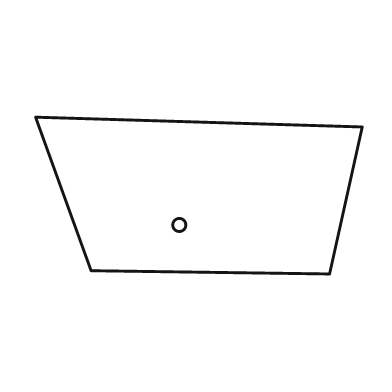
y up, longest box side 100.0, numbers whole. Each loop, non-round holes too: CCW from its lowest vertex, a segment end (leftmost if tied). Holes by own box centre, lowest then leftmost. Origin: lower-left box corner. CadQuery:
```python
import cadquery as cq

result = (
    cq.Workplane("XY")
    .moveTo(90.0, 0.0)
    .lineTo(100.0, 45.0)
    .lineTo(0.0, 48.0)
    .lineTo(17.0, 1.0)
    .close()
    .moveTo(44.0, 15.0)
    .circle(2.0)
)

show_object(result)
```